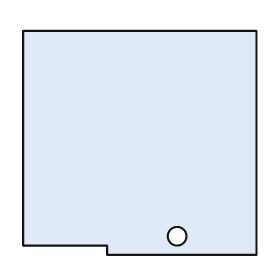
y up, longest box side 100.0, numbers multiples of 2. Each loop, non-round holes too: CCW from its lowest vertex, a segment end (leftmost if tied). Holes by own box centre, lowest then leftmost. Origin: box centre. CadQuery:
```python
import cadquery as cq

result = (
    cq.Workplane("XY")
    .moveTo(-14.0, -48.0)
    .lineTo(50.0, -48.0)
    .lineTo(50.0, 48.0)
    .lineTo(-50.0, 48.0)
    .lineTo(-50.0, -44.0)
    .lineTo(-14.0, -44.0)
    .close()
    .moveTo(16.0, -40.0)
    .circle(4.0)
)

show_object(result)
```